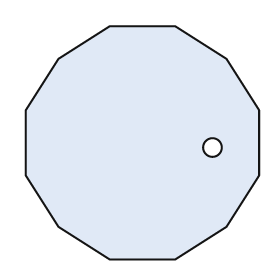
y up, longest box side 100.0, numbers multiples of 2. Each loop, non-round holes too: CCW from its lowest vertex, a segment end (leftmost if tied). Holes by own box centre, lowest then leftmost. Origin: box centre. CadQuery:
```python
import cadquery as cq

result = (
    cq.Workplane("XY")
    .moveTo(-14.0, -50.0)
    .lineTo(14.0, -50.0)
    .lineTo(36.0, -36.0)
    .lineTo(50.0, -14.0)
    .lineTo(50.0, 14.0)
    .lineTo(36.0, 36.0)
    .lineTo(14.0, 50.0)
    .lineTo(-14.0, 50.0)
    .lineTo(-36.0, 36.0)
    .lineTo(-50.0, 14.0)
    .lineTo(-50.0, -14.0)
    .lineTo(-36.0, -36.0)
    .close()
    .moveTo(30.0, -2.0)
    .circle(4.0)
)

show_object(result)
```